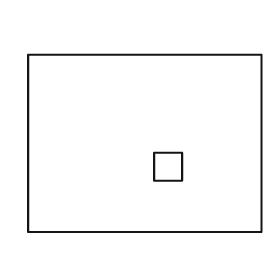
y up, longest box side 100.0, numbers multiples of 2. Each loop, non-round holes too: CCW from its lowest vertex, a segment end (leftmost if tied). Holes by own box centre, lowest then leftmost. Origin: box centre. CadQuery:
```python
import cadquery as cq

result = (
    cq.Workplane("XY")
    .moveTo(-50.0, -38.0)
    .lineTo(50.0, -38.0)
    .lineTo(50.0, 38.0)
    .lineTo(-50.0, 38.0)
    .close()
    .moveTo(4.0, -16.0)
    .lineTo(16.0, -16.0)
    .lineTo(16.0, -4.0)
    .lineTo(4.0, -4.0)
    .close()
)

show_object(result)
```